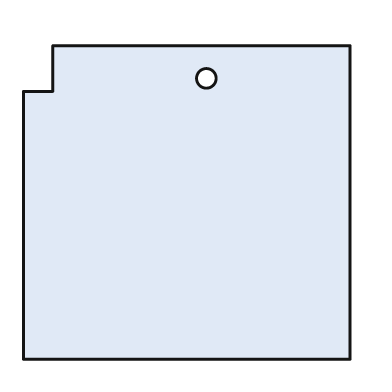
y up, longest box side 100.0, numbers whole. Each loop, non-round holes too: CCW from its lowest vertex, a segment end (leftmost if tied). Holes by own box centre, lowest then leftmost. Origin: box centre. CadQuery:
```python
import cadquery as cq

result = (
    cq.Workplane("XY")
    .moveTo(-50.0, -48.0)
    .lineTo(50.0, -48.0)
    .lineTo(50.0, 48.0)
    .lineTo(-41.0, 48.0)
    .lineTo(-41.0, 34.0)
    .lineTo(-50.0, 34.0)
    .close()
    .moveTo(6.0, 38.0)
    .circle(3.0)
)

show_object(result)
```